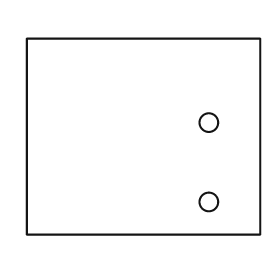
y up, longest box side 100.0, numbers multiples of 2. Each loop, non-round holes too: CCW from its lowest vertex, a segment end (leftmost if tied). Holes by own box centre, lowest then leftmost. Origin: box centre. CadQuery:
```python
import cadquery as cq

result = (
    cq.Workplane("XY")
    .moveTo(-50.0, -42.0)
    .lineTo(50.0, -42.0)
    .lineTo(50.0, 42.0)
    .lineTo(-50.0, 42.0)
    .close()
    .moveTo(28.0, -28.0)
    .circle(4.0)
    .moveTo(28.0, 6.0)
    .circle(4.0)
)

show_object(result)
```